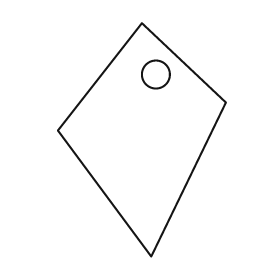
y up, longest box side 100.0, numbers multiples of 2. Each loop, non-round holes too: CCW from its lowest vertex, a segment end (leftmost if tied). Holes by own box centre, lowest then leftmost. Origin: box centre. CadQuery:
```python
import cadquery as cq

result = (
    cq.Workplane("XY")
    .moveTo(4.0, -50.0)
    .lineTo(36.0, 16.0)
    .lineTo(0.0, 50.0)
    .lineTo(-36.0, 4.0)
    .close()
    .moveTo(6.0, 28.0)
    .circle(6.0)
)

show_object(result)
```